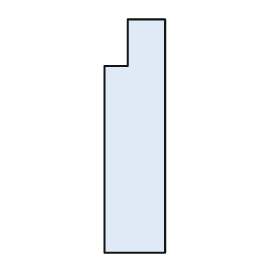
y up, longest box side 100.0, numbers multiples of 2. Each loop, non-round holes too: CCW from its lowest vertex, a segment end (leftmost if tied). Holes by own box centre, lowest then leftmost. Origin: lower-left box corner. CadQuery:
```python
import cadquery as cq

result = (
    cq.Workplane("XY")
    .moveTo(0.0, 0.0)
    .lineTo(26.0, 0.0)
    .lineTo(26.0, 100.0)
    .lineTo(10.0, 100.0)
    .lineTo(10.0, 80.0)
    .lineTo(0.0, 80.0)
    .close()
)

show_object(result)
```